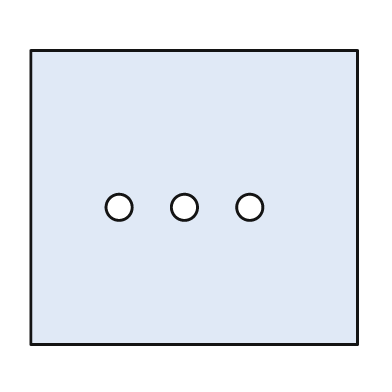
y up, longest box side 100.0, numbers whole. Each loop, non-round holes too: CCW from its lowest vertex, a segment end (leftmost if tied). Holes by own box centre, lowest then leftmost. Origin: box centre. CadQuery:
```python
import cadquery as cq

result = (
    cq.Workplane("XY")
    .moveTo(-50.0, -45.0)
    .lineTo(50.0, -45.0)
    .lineTo(50.0, 45.0)
    .lineTo(-50.0, 45.0)
    .close()
    .moveTo(-23.0, -3.0)
    .circle(4.0)
    .moveTo(-3.0, -3.0)
    .circle(4.0)
    .moveTo(17.0, -3.0)
    .circle(4.0)
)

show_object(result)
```